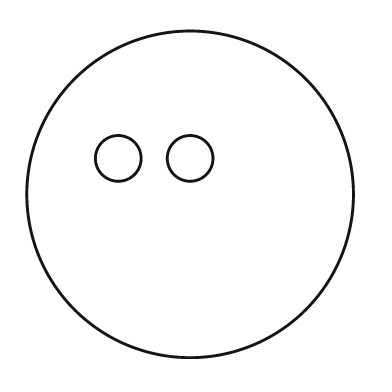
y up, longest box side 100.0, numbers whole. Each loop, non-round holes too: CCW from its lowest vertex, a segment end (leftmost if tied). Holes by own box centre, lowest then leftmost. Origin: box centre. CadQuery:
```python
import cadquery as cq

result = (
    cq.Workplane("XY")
    .moveTo(0.0, 0.0)
    .circle(50.0)
    .moveTo(-22.0, 11.0)
    .circle(7.0)
    .moveTo(0.0, 11.0)
    .circle(7.0)
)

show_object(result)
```